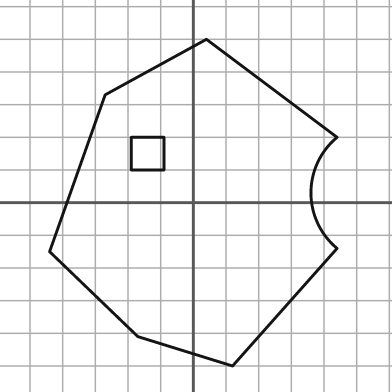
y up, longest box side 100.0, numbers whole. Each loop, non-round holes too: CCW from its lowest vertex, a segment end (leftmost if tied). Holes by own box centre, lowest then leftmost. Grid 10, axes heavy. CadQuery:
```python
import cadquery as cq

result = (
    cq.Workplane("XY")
    .moveTo(12.0, -50.0)
    .lineTo(44.0, -14.0)
    .threePointArc((36.0, 3.0), (44.0, 20.0))
    .lineTo(4.0, 50.0)
    .lineTo(-27.0, 33.0)
    .lineTo(-44.0, -15.0)
    .lineTo(-17.0, -41.0)
    .close()
    .moveTo(-19.0, 10.0)
    .lineTo(-9.0, 10.0)
    .lineTo(-9.0, 20.0)
    .lineTo(-19.0, 20.0)
    .close()
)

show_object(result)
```